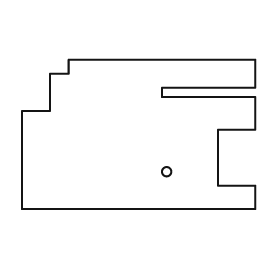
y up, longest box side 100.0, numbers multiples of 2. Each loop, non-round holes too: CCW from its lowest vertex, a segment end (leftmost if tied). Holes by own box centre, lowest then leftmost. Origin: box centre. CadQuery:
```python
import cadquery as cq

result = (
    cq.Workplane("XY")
    .moveTo(-50.0, -32.0)
    .lineTo(50.0, -32.0)
    .lineTo(50.0, -22.0)
    .lineTo(34.0, -22.0)
    .lineTo(34.0, 2.0)
    .lineTo(50.0, 2.0)
    .lineTo(50.0, 16.0)
    .lineTo(10.0, 16.0)
    .lineTo(10.0, 20.0)
    .lineTo(50.0, 20.0)
    .lineTo(50.0, 32.0)
    .lineTo(-30.0, 32.0)
    .lineTo(-30.0, 26.0)
    .lineTo(-38.0, 26.0)
    .lineTo(-38.0, 10.0)
    .lineTo(-50.0, 10.0)
    .close()
    .moveTo(12.0, -16.0)
    .circle(2.0)
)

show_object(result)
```